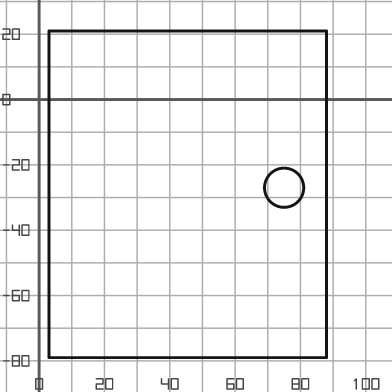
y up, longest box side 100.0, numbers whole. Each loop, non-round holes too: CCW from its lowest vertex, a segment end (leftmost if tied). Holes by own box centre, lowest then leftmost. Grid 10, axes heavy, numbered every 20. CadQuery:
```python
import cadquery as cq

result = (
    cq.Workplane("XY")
    .moveTo(3.0, -79.0)
    .lineTo(88.0, -79.0)
    .lineTo(88.0, 21.0)
    .lineTo(3.0, 21.0)
    .close()
    .moveTo(75.0, -27.0)
    .circle(6.0)
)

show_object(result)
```